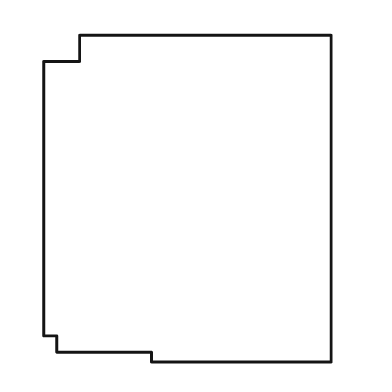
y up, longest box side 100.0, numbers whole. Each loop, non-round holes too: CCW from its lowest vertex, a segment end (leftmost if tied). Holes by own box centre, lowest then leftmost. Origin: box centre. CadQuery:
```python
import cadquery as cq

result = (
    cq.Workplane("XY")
    .moveTo(-11.0, -50.0)
    .lineTo(44.0, -50.0)
    .lineTo(44.0, 50.0)
    .lineTo(-33.0, 50.0)
    .lineTo(-33.0, 42.0)
    .lineTo(-44.0, 42.0)
    .lineTo(-44.0, -42.0)
    .lineTo(-40.0, -42.0)
    .lineTo(-40.0, -47.0)
    .lineTo(-11.0, -47.0)
    .close()
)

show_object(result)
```